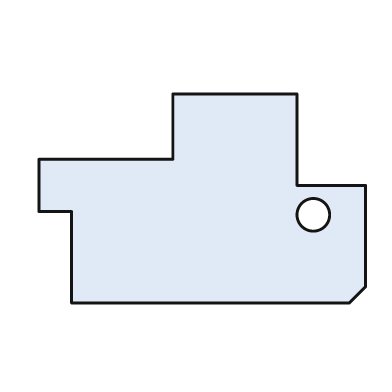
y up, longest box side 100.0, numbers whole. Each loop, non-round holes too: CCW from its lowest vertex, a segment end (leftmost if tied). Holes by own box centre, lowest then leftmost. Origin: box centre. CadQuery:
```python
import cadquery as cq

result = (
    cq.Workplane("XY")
    .moveTo(-40.0, -32.0)
    .lineTo(45.0, -32.0)
    .lineTo(50.0, -27.0)
    .lineTo(50.0, 4.0)
    .lineTo(29.0, 4.0)
    .lineTo(29.0, 32.0)
    .lineTo(-9.0, 32.0)
    .lineTo(-9.0, 12.0)
    .lineTo(-50.0, 12.0)
    .lineTo(-50.0, -4.0)
    .lineTo(-40.0, -4.0)
    .close()
    .moveTo(34.0, -5.0)
    .circle(5.0)
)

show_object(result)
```